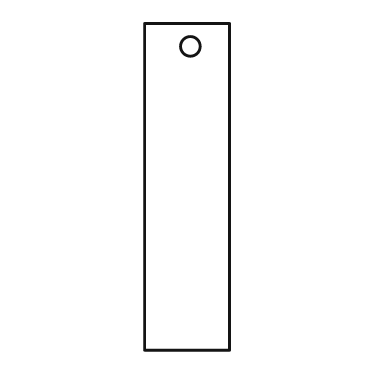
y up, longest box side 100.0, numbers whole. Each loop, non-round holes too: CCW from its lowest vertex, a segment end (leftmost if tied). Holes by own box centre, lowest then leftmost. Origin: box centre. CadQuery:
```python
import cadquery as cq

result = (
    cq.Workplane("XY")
    .moveTo(-13.0, -50.0)
    .lineTo(13.0, -50.0)
    .lineTo(13.0, 50.0)
    .lineTo(-13.0, 50.0)
    .close()
    .moveTo(1.0, 43.0)
    .circle(3.0)
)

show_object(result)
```